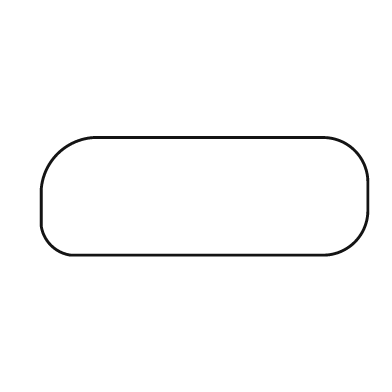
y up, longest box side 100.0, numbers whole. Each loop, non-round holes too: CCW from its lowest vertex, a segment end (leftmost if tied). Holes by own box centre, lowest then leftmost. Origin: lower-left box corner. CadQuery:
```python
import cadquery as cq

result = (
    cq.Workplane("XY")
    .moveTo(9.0, 0.0)
    .lineTo(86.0, 0.0)
    .threePointArc((96.0, 4.0), (100.0, 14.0))
    .lineTo(100.0, 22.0)
    .threePointArc((96.0, 32.0), (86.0, 36.0))
    .lineTo(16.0, 36.0)
    .threePointArc((5.0, 31.0), (0.0, 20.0))
    .lineTo(0.0, 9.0)
    .threePointArc((3.0, 3.0), (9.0, 0.0))
    .close()
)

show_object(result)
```